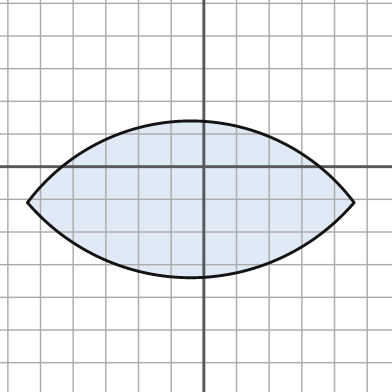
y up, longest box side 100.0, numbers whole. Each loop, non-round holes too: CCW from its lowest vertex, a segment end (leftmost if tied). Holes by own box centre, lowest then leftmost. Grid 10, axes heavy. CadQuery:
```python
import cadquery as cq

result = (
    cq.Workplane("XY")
    .moveTo(-54.0, -11.0)
    .threePointArc((-4.0, -34.0), (46.0, -11.0))
    .threePointArc((-4.0, 14.0), (-54.0, -11.0))
    .close()
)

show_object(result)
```